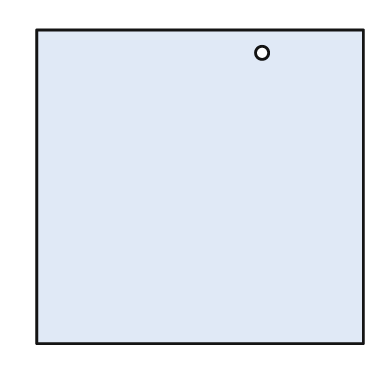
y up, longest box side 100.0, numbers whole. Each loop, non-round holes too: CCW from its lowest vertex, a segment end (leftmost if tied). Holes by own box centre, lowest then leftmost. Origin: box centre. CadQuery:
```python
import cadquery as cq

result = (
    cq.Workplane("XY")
    .moveTo(-50.0, -48.0)
    .lineTo(50.0, -48.0)
    .lineTo(50.0, 48.0)
    .lineTo(-50.0, 48.0)
    .close()
    .moveTo(19.0, 41.0)
    .circle(2.0)
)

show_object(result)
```